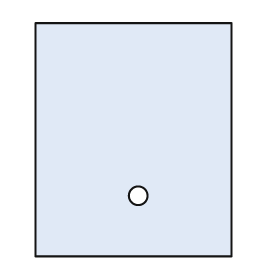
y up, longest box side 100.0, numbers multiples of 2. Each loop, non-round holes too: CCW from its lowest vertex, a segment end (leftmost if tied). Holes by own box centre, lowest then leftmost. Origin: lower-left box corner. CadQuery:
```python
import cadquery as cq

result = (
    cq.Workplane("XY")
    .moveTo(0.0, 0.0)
    .lineTo(84.0, 0.0)
    .lineTo(84.0, 100.0)
    .lineTo(0.0, 100.0)
    .close()
    .moveTo(44.0, 26.0)
    .circle(4.0)
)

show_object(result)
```